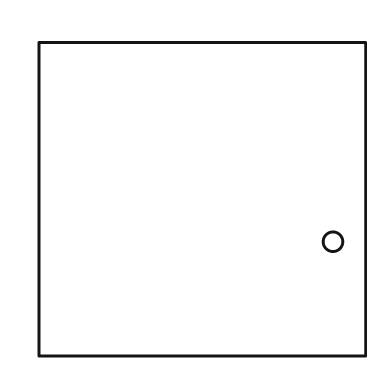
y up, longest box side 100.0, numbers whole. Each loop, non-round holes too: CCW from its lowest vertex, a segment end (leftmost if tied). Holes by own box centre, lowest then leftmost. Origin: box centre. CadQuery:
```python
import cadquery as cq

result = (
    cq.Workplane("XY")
    .moveTo(-50.0, -48.0)
    .lineTo(50.0, -48.0)
    .lineTo(50.0, 48.0)
    .lineTo(-50.0, 48.0)
    .close()
    .moveTo(40.0, -13.0)
    .circle(3.0)
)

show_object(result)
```